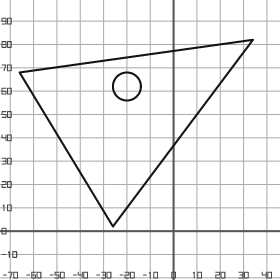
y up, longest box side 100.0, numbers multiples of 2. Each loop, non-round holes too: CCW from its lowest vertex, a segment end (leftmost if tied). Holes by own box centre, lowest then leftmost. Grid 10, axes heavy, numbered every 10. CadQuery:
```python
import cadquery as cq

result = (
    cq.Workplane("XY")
    .moveTo(-26.0, 2.0)
    .lineTo(34.0, 82.0)
    .lineTo(-66.0, 68.0)
    .close()
    .moveTo(-20.0, 62.0)
    .circle(6.0)
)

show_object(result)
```